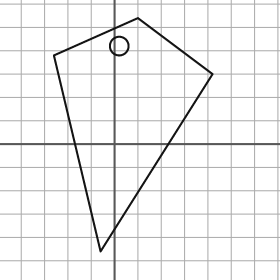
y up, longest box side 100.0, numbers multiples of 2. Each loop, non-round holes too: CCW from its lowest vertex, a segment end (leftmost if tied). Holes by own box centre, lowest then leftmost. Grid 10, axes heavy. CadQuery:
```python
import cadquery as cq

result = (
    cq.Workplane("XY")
    .moveTo(-6.0, -46.0)
    .lineTo(42.0, 30.0)
    .lineTo(10.0, 54.0)
    .lineTo(-26.0, 38.0)
    .close()
    .moveTo(2.0, 42.0)
    .circle(4.0)
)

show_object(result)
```